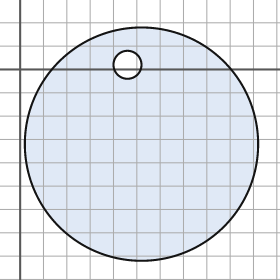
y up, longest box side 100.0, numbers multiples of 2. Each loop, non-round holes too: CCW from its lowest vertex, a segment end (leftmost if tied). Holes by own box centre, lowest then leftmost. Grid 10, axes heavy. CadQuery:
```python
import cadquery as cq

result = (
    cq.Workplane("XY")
    .moveTo(52.0, -32.0)
    .circle(50.0)
    .moveTo(46.0, 2.0)
    .circle(6.0)
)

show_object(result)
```